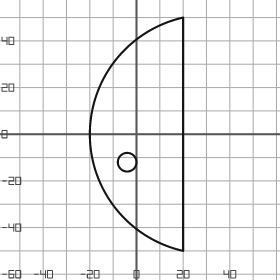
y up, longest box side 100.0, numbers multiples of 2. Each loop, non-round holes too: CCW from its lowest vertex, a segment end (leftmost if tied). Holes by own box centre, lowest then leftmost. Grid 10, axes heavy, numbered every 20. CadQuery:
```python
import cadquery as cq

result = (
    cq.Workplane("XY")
    .moveTo(20.0, -50.0)
    .lineTo(20.0, 50.0)
    .threePointArc((-20.0, 0.0), (20.0, -50.0))
    .close()
    .moveTo(-4.0, -12.0)
    .circle(4.0)
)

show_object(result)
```